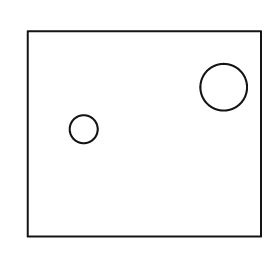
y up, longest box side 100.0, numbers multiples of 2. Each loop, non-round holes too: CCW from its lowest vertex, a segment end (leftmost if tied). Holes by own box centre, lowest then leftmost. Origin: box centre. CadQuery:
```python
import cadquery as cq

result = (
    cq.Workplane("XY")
    .moveTo(-50.0, -44.0)
    .lineTo(50.0, -44.0)
    .lineTo(50.0, 44.0)
    .lineTo(-50.0, 44.0)
    .close()
    .moveTo(-26.0, 2.0)
    .circle(6.0)
    .moveTo(34.0, 20.0)
    .circle(10.0)
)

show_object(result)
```